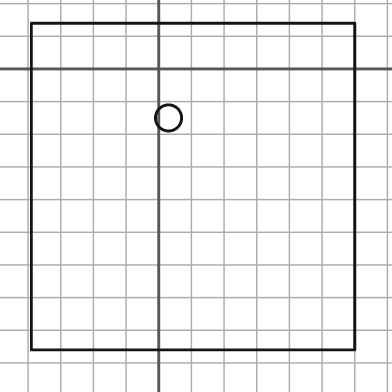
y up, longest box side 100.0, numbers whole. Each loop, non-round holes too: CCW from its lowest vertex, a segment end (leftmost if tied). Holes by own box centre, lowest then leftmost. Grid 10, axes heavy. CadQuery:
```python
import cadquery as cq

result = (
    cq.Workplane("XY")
    .moveTo(-39.0, -86.0)
    .lineTo(60.0, -86.0)
    .lineTo(60.0, 14.0)
    .lineTo(-39.0, 14.0)
    .close()
    .moveTo(3.0, -15.0)
    .circle(4.0)
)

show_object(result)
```